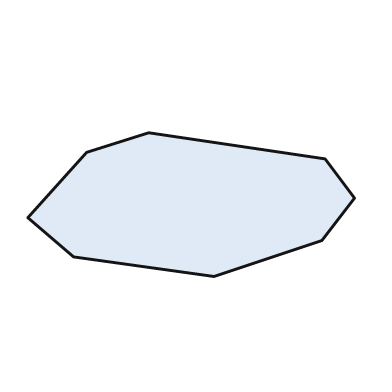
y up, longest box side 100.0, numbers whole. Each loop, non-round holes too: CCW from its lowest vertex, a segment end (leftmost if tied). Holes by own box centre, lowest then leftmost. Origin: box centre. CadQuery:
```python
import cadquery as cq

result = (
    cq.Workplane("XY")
    .moveTo(7.0, -22.0)
    .lineTo(40.0, -11.0)
    .lineTo(50.0, 2.0)
    .lineTo(41.0, 14.0)
    .lineTo(-13.0, 22.0)
    .lineTo(-32.0, 16.0)
    .lineTo(-50.0, -4.0)
    .lineTo(-36.0, -16.0)
    .close()
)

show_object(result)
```